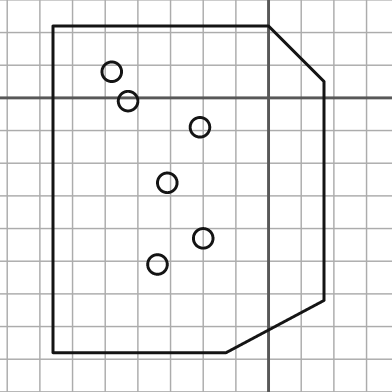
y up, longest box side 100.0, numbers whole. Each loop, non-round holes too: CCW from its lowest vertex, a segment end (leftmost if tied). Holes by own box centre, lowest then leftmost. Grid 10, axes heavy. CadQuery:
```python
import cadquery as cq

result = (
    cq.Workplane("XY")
    .moveTo(-66.0, -78.0)
    .lineTo(-13.0, -78.0)
    .lineTo(17.0, -62.0)
    .lineTo(17.0, 5.0)
    .lineTo(0.0, 22.0)
    .lineTo(-66.0, 22.0)
    .close()
    .moveTo(-34.0, -51.0)
    .circle(3.0)
    .moveTo(-20.0, -43.0)
    .circle(3.0)
    .moveTo(-31.0, -26.0)
    .circle(3.0)
    .moveTo(-21.0, -9.0)
    .circle(3.0)
    .moveTo(-43.0, -1.0)
    .circle(3.0)
    .moveTo(-48.0, 8.0)
    .circle(3.0)
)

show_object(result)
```